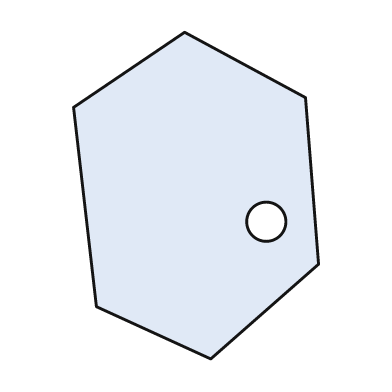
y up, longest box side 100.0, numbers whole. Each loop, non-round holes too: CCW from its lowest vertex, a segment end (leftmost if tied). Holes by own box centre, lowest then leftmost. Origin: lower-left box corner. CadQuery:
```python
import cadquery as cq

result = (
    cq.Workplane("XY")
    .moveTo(42.0, 0.0)
    .lineTo(75.0, 29.0)
    .lineTo(71.0, 80.0)
    .lineTo(34.0, 100.0)
    .lineTo(0.0, 77.0)
    .lineTo(7.0, 16.0)
    .close()
    .moveTo(59.0, 42.0)
    .circle(6.0)
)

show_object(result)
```